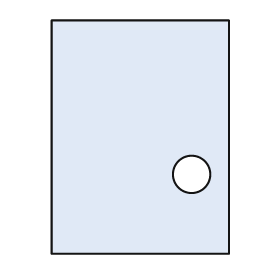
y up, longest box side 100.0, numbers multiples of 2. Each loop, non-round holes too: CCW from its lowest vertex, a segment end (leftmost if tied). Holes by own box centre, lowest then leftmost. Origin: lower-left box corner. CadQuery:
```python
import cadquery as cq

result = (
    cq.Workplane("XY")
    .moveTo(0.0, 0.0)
    .lineTo(76.0, 0.0)
    .lineTo(76.0, 100.0)
    .lineTo(0.0, 100.0)
    .close()
    .moveTo(60.0, 34.0)
    .circle(8.0)
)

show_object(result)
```